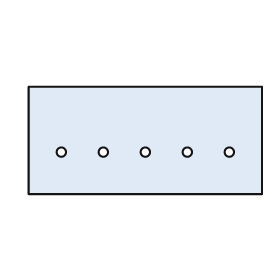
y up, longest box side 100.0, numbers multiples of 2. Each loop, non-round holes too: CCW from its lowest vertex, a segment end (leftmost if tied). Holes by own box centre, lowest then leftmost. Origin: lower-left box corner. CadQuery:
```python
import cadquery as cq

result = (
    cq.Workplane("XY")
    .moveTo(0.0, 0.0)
    .lineTo(100.0, 0.0)
    .lineTo(100.0, 46.0)
    .lineTo(0.0, 46.0)
    .close()
    .moveTo(14.0, 18.0)
    .circle(2.0)
    .moveTo(32.0, 18.0)
    .circle(2.0)
    .moveTo(50.0, 18.0)
    .circle(2.0)
    .moveTo(68.0, 18.0)
    .circle(2.0)
    .moveTo(86.0, 18.0)
    .circle(2.0)
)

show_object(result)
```